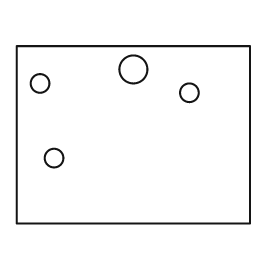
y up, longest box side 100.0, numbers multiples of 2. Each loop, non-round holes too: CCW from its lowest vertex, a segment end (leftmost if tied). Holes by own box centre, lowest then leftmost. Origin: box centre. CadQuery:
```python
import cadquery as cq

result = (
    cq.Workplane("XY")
    .moveTo(-50.0, -38.0)
    .lineTo(50.0, -38.0)
    .lineTo(50.0, 38.0)
    .lineTo(-50.0, 38.0)
    .close()
    .moveTo(-34.0, -10.0)
    .circle(4.0)
    .moveTo(24.0, 18.0)
    .circle(4.0)
    .moveTo(-40.0, 22.0)
    .circle(4.0)
    .moveTo(0.0, 28.0)
    .circle(6.0)
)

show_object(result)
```